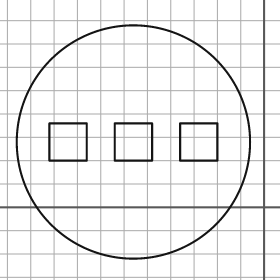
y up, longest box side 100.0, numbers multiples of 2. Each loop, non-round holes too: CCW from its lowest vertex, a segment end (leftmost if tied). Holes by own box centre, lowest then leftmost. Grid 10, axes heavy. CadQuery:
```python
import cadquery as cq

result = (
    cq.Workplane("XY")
    .moveTo(-56.0, 28.0)
    .circle(50.0)
    .moveTo(-92.0, 20.0)
    .lineTo(-76.0, 20.0)
    .lineTo(-76.0, 36.0)
    .lineTo(-92.0, 36.0)
    .close()
    .moveTo(-64.0, 20.0)
    .lineTo(-48.0, 20.0)
    .lineTo(-48.0, 36.0)
    .lineTo(-64.0, 36.0)
    .close()
    .moveTo(-36.0, 20.0)
    .lineTo(-20.0, 20.0)
    .lineTo(-20.0, 36.0)
    .lineTo(-36.0, 36.0)
    .close()
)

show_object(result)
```